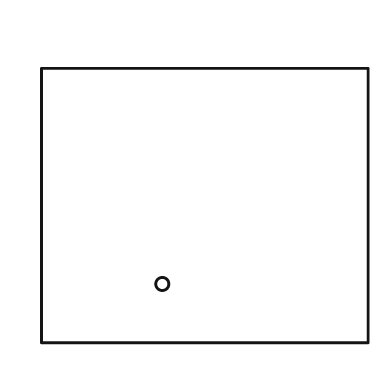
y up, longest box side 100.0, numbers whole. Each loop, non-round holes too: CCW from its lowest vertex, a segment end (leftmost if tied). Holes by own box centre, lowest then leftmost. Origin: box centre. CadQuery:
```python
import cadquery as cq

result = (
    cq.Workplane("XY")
    .moveTo(-50.0, -42.0)
    .lineTo(50.0, -42.0)
    .lineTo(50.0, 42.0)
    .lineTo(-50.0, 42.0)
    .close()
    .moveTo(-13.0, -24.0)
    .circle(2.0)
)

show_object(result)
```